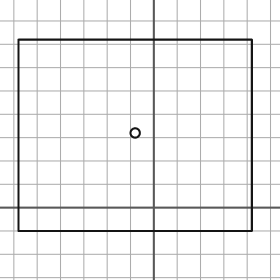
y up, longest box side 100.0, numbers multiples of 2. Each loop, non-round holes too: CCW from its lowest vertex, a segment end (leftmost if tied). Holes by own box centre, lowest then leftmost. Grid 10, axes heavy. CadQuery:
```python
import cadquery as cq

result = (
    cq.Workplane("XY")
    .moveTo(-58.0, -10.0)
    .lineTo(42.0, -10.0)
    .lineTo(42.0, 72.0)
    .lineTo(-58.0, 72.0)
    .close()
    .moveTo(-8.0, 32.0)
    .circle(2.0)
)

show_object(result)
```